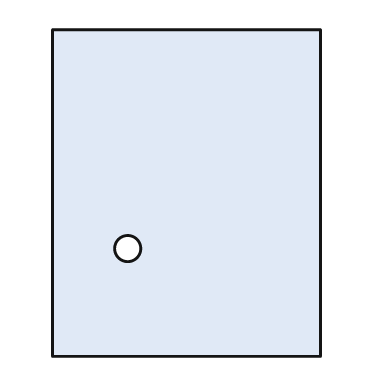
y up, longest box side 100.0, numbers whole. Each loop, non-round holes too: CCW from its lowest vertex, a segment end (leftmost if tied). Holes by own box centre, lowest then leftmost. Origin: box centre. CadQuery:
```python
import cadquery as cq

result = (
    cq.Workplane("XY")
    .moveTo(-41.0, -50.0)
    .lineTo(41.0, -50.0)
    .lineTo(41.0, 50.0)
    .lineTo(-41.0, 50.0)
    .close()
    .moveTo(-18.0, -17.0)
    .circle(4.0)
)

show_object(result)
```